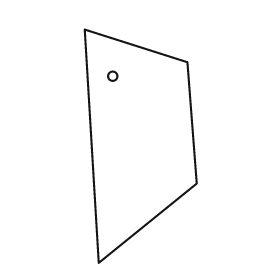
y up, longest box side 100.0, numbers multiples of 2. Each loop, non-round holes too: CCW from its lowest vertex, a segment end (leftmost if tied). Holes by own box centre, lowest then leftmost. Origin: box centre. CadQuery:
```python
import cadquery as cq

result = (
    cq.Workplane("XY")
    .moveTo(-18.0, -50.0)
    .lineTo(24.0, -16.0)
    .lineTo(20.0, 36.0)
    .lineTo(-24.0, 50.0)
    .close()
    .moveTo(-12.0, 30.0)
    .circle(2.0)
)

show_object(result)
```